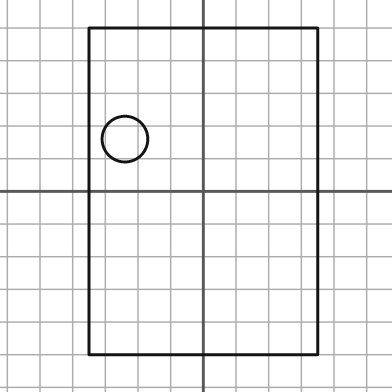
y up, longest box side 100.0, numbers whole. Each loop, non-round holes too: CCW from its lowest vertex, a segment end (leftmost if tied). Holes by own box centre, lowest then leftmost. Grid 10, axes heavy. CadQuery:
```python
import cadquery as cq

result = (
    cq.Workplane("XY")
    .moveTo(-35.0, -50.0)
    .lineTo(35.0, -50.0)
    .lineTo(35.0, 50.0)
    .lineTo(-35.0, 50.0)
    .close()
    .moveTo(-24.0, 16.0)
    .circle(7.0)
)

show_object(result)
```